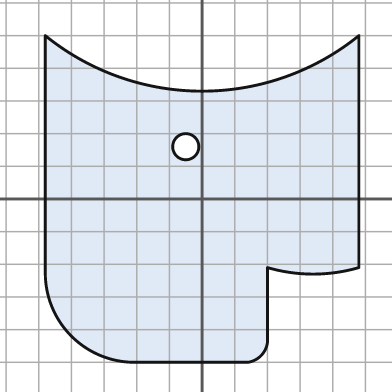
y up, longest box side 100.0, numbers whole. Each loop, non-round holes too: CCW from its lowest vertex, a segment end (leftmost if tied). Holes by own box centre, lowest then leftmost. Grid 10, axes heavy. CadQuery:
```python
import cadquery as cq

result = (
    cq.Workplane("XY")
    .moveTo(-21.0, -50.0)
    .lineTo(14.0, -50.0)
    .threePointArc((18.0, -48.0), (20.0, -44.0))
    .lineTo(20.0, -21.0)
    .threePointArc((34.0, -23.0), (48.0, -21.0))
    .lineTo(48.0, 50.0)
    .threePointArc((0.0, 33.0), (-48.0, 50.0))
    .lineTo(-48.0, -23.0)
    .threePointArc((-40.0, -42.0), (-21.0, -50.0))
    .close()
    .moveTo(-5.0, 16.0)
    .circle(4.0)
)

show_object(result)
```